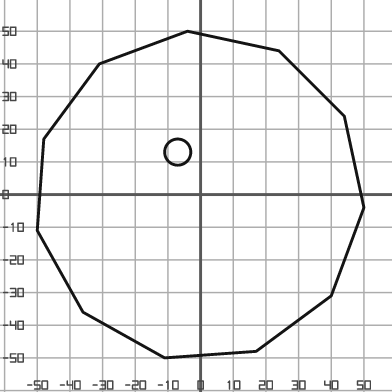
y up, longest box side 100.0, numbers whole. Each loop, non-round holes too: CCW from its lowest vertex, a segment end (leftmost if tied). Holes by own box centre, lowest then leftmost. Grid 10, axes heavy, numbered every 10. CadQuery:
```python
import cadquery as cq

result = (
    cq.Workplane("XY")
    .moveTo(-11.0, -50.0)
    .lineTo(17.0, -48.0)
    .lineTo(40.0, -31.0)
    .lineTo(50.0, -4.0)
    .lineTo(44.0, 24.0)
    .lineTo(24.0, 44.0)
    .lineTo(-4.0, 50.0)
    .lineTo(-31.0, 40.0)
    .lineTo(-48.0, 17.0)
    .lineTo(-50.0, -11.0)
    .lineTo(-36.0, -36.0)
    .close()
    .moveTo(-7.0, 13.0)
    .circle(4.0)
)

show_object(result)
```